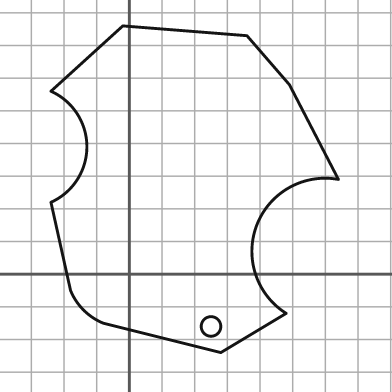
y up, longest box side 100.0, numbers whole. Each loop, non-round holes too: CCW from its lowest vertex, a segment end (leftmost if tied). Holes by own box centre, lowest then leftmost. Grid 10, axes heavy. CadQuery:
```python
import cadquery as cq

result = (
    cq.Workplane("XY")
    .moveTo(28.0, -24.0)
    .lineTo(48.0, -12.0)
    .threePointArc((39.0, 15.0), (64.0, 29.0))
    .lineTo(49.0, 58.0)
    .lineTo(36.0, 73.0)
    .lineTo(-2.0, 76.0)
    .lineTo(-24.0, 56.0)
    .threePointArc((-13.0, 39.0), (-24.0, 22.0))
    .lineTo(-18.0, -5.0)
    .threePointArc((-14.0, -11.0), (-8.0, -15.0))
    .close()
    .moveTo(25.0, -16.0)
    .circle(3.0)
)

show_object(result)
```